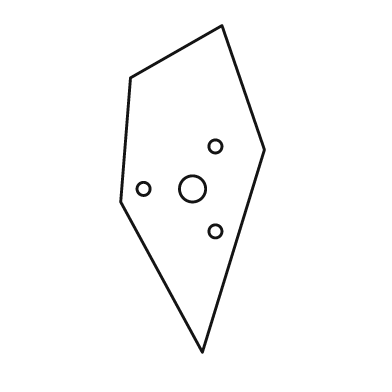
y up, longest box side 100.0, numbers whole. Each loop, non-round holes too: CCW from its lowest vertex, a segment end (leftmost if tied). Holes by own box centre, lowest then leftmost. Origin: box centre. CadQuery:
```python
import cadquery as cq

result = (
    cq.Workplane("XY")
    .moveTo(3.0, -50.0)
    .lineTo(22.0, 12.0)
    .lineTo(9.0, 50.0)
    .lineTo(-19.0, 34.0)
    .lineTo(-22.0, -4.0)
    .close()
    .moveTo(7.0, -13.0)
    .circle(2.0)
    .moveTo(-15.0, 0.0)
    .circle(2.0)
    .moveTo(0.0, 0.0)
    .circle(4.0)
    .moveTo(7.0, 13.0)
    .circle(2.0)
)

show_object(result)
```